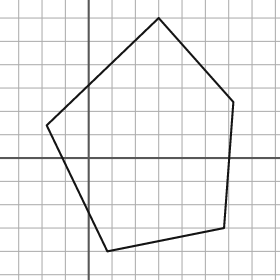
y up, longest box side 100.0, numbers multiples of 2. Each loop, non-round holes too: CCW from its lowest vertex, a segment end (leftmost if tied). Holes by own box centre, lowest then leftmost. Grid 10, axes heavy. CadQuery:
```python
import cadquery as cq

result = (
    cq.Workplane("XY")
    .moveTo(8.0, -40.0)
    .lineTo(58.0, -30.0)
    .lineTo(62.0, 24.0)
    .lineTo(30.0, 60.0)
    .lineTo(-18.0, 14.0)
    .close()
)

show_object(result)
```